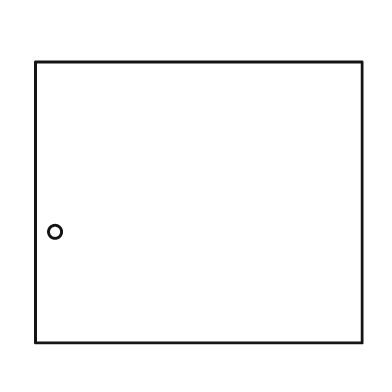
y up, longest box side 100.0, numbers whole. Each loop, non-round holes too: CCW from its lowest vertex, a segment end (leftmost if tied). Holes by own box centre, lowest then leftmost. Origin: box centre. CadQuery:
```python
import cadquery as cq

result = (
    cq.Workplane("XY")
    .moveTo(-50.0, -43.0)
    .lineTo(50.0, -43.0)
    .lineTo(50.0, 43.0)
    .lineTo(-50.0, 43.0)
    .close()
    .moveTo(-44.0, -9.0)
    .circle(2.0)
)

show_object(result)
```